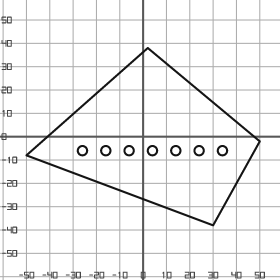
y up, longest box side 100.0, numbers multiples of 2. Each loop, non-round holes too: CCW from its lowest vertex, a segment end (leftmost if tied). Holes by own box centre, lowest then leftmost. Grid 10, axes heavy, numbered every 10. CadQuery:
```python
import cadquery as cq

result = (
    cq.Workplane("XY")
    .moveTo(30.0, -38.0)
    .lineTo(50.0, -2.0)
    .lineTo(2.0, 38.0)
    .lineTo(-50.0, -8.0)
    .close()
    .moveTo(-26.0, -6.0)
    .circle(2.0)
    .moveTo(-16.0, -6.0)
    .circle(2.0)
    .moveTo(-6.0, -6.0)
    .circle(2.0)
    .moveTo(4.0, -6.0)
    .circle(2.0)
    .moveTo(14.0, -6.0)
    .circle(2.0)
    .moveTo(24.0, -6.0)
    .circle(2.0)
    .moveTo(34.0, -6.0)
    .circle(2.0)
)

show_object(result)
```